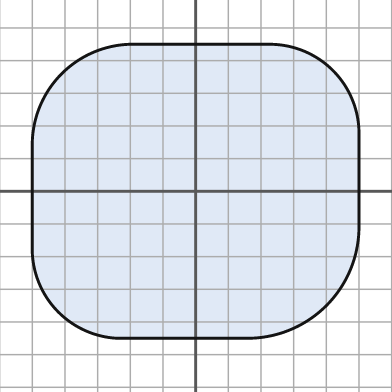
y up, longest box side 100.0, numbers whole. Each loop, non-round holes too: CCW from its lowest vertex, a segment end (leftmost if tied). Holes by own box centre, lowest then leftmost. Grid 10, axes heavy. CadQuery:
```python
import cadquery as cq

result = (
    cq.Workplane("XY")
    .moveTo(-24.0, -45.0)
    .lineTo(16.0, -45.0)
    .threePointArc((40.0, -35.0), (50.0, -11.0))
    .lineTo(50.0, 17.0)
    .threePointArc((42.0, 37.0), (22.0, 45.0))
    .lineTo(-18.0, 45.0)
    .threePointArc((-41.0, 36.0), (-50.0, 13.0))
    .lineTo(-50.0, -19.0)
    .threePointArc((-42.0, -37.0), (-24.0, -45.0))
    .close()
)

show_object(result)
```